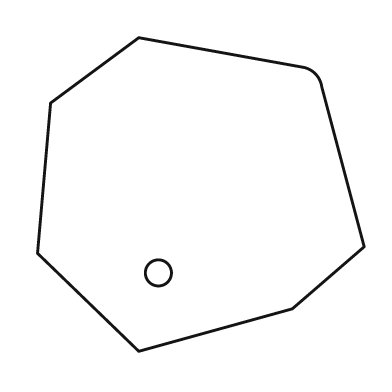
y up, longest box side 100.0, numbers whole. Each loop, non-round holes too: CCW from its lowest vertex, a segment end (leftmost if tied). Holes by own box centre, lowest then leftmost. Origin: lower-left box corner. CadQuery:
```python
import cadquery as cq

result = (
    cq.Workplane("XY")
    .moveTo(31.0, 0.0)
    .lineTo(78.0, 13.0)
    .lineTo(100.0, 32.0)
    .lineTo(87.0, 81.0)
    .threePointArc((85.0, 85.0), (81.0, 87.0))
    .lineTo(31.0, 96.0)
    .lineTo(4.0, 76.0)
    .lineTo(0.0, 30.0)
    .close()
    .moveTo(37.0, 24.0)
    .circle(4.0)
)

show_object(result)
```